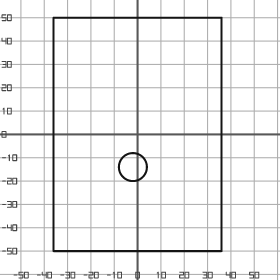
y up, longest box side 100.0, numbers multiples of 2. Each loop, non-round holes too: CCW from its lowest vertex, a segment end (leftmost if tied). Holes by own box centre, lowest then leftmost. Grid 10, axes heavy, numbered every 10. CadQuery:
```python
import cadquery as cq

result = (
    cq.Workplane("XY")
    .moveTo(-36.0, -50.0)
    .lineTo(36.0, -50.0)
    .lineTo(36.0, 50.0)
    .lineTo(-36.0, 50.0)
    .close()
    .moveTo(-2.0, -14.0)
    .circle(6.0)
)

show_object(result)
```